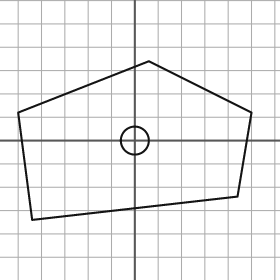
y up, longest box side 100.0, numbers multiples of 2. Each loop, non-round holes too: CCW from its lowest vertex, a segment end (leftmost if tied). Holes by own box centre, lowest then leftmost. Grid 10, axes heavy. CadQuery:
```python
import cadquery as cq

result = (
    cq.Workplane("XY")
    .moveTo(-44.0, -34.0)
    .lineTo(44.0, -24.0)
    .lineTo(50.0, 12.0)
    .lineTo(6.0, 34.0)
    .lineTo(-50.0, 12.0)
    .close()
    .moveTo(0.0, 0.0)
    .circle(6.0)
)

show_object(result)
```